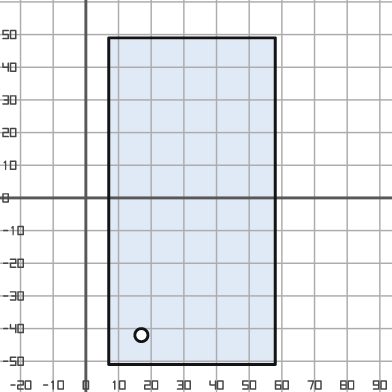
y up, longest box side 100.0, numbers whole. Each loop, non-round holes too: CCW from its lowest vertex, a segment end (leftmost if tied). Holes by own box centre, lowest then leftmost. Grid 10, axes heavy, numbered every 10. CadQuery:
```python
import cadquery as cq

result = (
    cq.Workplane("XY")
    .moveTo(7.0, -51.0)
    .lineTo(58.0, -51.0)
    .lineTo(58.0, 49.0)
    .lineTo(7.0, 49.0)
    .close()
    .moveTo(17.0, -42.0)
    .circle(2.0)
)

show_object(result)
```